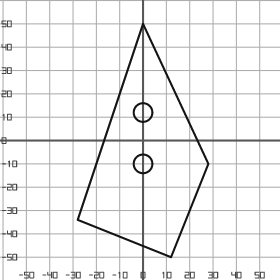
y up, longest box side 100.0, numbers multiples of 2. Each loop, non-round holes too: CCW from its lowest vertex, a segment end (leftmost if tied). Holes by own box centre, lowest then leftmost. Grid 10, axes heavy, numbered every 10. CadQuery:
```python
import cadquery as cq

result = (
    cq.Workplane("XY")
    .moveTo(12.0, -50.0)
    .lineTo(28.0, -10.0)
    .lineTo(0.0, 50.0)
    .lineTo(-28.0, -34.0)
    .close()
    .moveTo(0.0, -10.0)
    .circle(4.0)
    .moveTo(0.0, 12.0)
    .circle(4.0)
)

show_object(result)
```